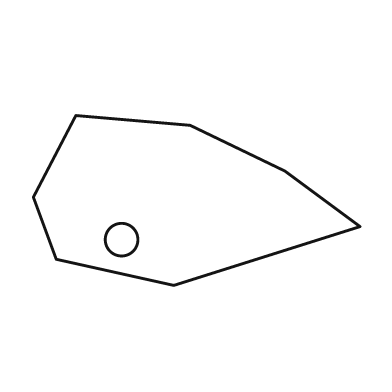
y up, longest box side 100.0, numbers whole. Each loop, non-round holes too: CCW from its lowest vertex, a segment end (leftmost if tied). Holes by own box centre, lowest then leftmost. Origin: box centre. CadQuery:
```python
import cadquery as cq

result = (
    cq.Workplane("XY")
    .moveTo(-7.0, -26.0)
    .lineTo(50.0, -8.0)
    .lineTo(27.0, 9.0)
    .lineTo(-2.0, 23.0)
    .lineTo(-37.0, 26.0)
    .lineTo(-50.0, 1.0)
    .lineTo(-43.0, -18.0)
    .close()
    .moveTo(-23.0, -12.0)
    .circle(5.0)
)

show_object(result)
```